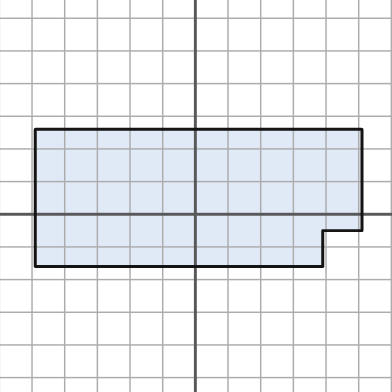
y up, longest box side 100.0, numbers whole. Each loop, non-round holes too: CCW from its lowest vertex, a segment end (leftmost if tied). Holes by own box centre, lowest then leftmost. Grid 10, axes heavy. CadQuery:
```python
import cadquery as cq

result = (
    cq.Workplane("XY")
    .moveTo(-49.0, -16.0)
    .lineTo(39.0, -16.0)
    .lineTo(39.0, -5.0)
    .lineTo(51.0, -5.0)
    .lineTo(51.0, 26.0)
    .lineTo(-49.0, 26.0)
    .close()
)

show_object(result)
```